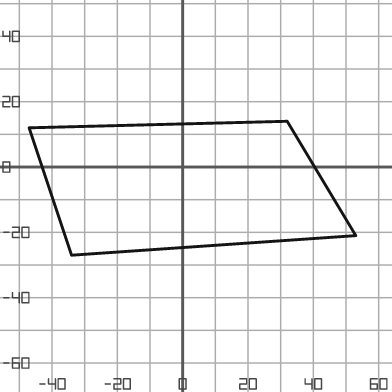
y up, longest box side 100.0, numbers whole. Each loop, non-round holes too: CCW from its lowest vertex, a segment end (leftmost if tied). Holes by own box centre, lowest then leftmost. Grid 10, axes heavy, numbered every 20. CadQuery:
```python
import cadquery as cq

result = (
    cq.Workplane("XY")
    .moveTo(-34.0, -27.0)
    .lineTo(53.0, -21.0)
    .lineTo(32.0, 14.0)
    .lineTo(-47.0, 12.0)
    .close()
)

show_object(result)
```